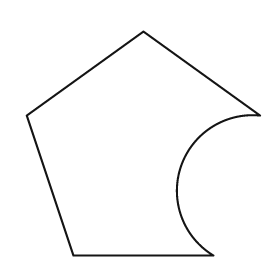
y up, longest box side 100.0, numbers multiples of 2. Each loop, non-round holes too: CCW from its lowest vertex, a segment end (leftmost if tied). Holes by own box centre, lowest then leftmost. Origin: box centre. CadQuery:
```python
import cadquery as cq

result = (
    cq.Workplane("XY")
    .moveTo(-30.0, -48.0)
    .lineTo(30.0, -48.0)
    .threePointArc((16.0, -10.0), (50.0, 12.0))
    .lineTo(0.0, 48.0)
    .lineTo(-50.0, 12.0)
    .close()
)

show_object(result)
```